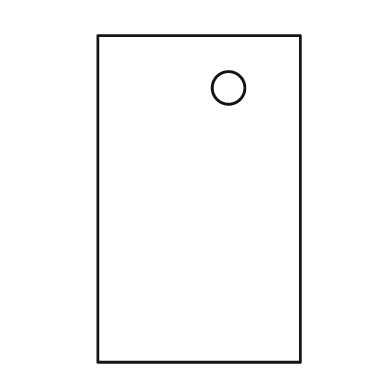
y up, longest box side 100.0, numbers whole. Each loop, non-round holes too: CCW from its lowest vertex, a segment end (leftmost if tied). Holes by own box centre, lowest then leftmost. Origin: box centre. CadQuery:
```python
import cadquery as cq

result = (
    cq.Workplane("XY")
    .moveTo(-31.0, -50.0)
    .lineTo(31.0, -50.0)
    .lineTo(31.0, 50.0)
    .lineTo(-31.0, 50.0)
    .close()
    .moveTo(9.0, 34.0)
    .circle(5.0)
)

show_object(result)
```